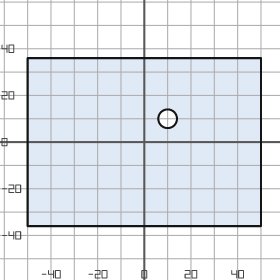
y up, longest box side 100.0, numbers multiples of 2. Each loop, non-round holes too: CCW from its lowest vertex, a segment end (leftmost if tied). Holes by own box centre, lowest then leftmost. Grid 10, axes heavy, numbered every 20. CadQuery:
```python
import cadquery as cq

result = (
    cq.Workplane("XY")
    .moveTo(-50.0, -36.0)
    .lineTo(50.0, -36.0)
    .lineTo(50.0, 36.0)
    .lineTo(-50.0, 36.0)
    .close()
    .moveTo(10.0, 10.0)
    .circle(4.0)
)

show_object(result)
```